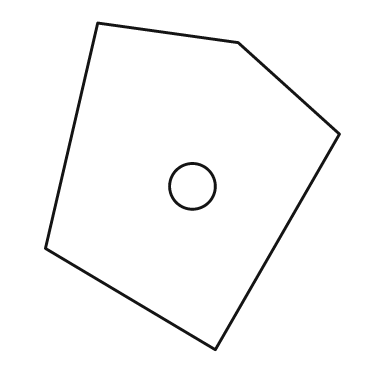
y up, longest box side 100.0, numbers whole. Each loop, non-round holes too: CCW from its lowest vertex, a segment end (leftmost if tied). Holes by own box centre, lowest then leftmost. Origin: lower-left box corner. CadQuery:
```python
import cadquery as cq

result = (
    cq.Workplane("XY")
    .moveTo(52.0, 0.0)
    .lineTo(90.0, 66.0)
    .lineTo(59.0, 94.0)
    .lineTo(16.0, 100.0)
    .lineTo(0.0, 31.0)
    .close()
    .moveTo(45.0, 50.0)
    .circle(7.0)
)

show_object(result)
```